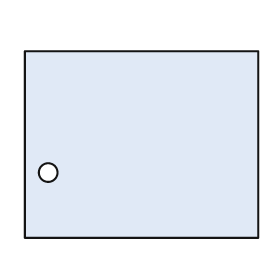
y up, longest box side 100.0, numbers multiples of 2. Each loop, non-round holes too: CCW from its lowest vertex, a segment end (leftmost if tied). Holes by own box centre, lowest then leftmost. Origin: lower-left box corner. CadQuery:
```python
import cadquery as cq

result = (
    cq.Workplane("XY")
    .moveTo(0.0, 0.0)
    .lineTo(100.0, 0.0)
    .lineTo(100.0, 80.0)
    .lineTo(0.0, 80.0)
    .close()
    .moveTo(10.0, 28.0)
    .circle(4.0)
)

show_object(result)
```